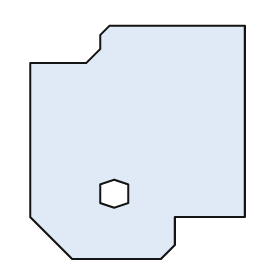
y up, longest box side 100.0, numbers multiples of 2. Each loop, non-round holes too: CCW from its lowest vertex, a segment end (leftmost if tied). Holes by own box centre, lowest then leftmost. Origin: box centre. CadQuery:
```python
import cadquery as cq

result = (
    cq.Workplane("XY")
    .moveTo(-28.0, -50.0)
    .lineTo(10.0, -50.0)
    .lineTo(16.0, -44.0)
    .lineTo(16.0, -32.0)
    .lineTo(46.0, -32.0)
    .lineTo(46.0, 50.0)
    .lineTo(-12.0, 50.0)
    .lineTo(-16.0, 46.0)
    .lineTo(-16.0, 40.0)
    .lineTo(-22.0, 34.0)
    .lineTo(-46.0, 34.0)
    .lineTo(-46.0, -32.0)
    .close()
    .moveTo(-10.0, -28.0)
    .lineTo(-4.0, -26.0)
    .lineTo(-4.0, -18.0)
    .lineTo(-10.0, -16.0)
    .lineTo(-16.0, -18.0)
    .lineTo(-16.0, -26.0)
    .close()
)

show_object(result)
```